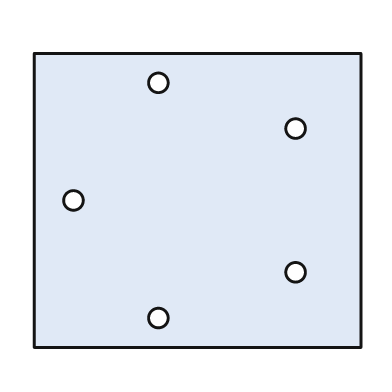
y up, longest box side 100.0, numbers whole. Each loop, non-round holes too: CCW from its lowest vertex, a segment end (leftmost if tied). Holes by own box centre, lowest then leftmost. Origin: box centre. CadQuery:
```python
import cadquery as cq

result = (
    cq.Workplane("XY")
    .moveTo(-50.0, -45.0)
    .lineTo(50.0, -45.0)
    .lineTo(50.0, 45.0)
    .lineTo(-50.0, 45.0)
    .close()
    .moveTo(-12.0, -36.0)
    .circle(3.0)
    .moveTo(30.0, -22.0)
    .circle(3.0)
    .moveTo(-38.0, 0.0)
    .circle(3.0)
    .moveTo(30.0, 22.0)
    .circle(3.0)
    .moveTo(-12.0, 36.0)
    .circle(3.0)
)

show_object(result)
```